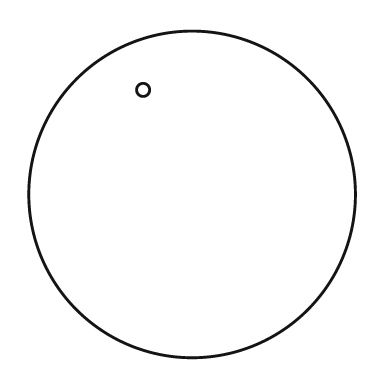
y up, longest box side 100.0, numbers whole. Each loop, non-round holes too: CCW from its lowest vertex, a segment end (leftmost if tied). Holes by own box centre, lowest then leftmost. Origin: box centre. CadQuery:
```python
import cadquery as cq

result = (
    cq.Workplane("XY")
    .moveTo(0.0, 0.0)
    .circle(50.0)
    .moveTo(-15.0, 32.0)
    .circle(2.0)
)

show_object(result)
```